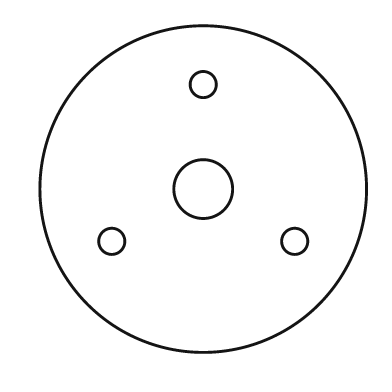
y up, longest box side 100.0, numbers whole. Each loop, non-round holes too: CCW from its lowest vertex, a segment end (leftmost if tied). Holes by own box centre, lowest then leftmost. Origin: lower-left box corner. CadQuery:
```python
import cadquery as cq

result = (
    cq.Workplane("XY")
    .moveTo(50.0, 50.0)
    .circle(50.0)
    .moveTo(22.0, 34.0)
    .circle(4.0)
    .moveTo(78.0, 34.0)
    .circle(4.0)
    .moveTo(50.0, 50.0)
    .circle(9.0)
    .moveTo(50.0, 82.0)
    .circle(4.0)
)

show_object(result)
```